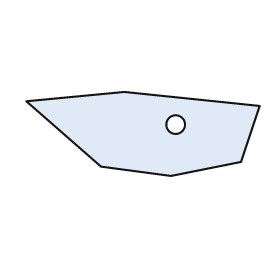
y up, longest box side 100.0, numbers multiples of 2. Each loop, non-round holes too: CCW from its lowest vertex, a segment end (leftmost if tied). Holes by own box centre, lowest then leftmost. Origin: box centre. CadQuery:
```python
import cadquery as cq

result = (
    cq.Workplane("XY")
    .moveTo(12.0, -18.0)
    .lineTo(42.0, -12.0)
    .lineTo(50.0, 12.0)
    .lineTo(-8.0, 18.0)
    .lineTo(-50.0, 14.0)
    .lineTo(-18.0, -14.0)
    .close()
    .moveTo(14.0, 4.0)
    .circle(4.0)
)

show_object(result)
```